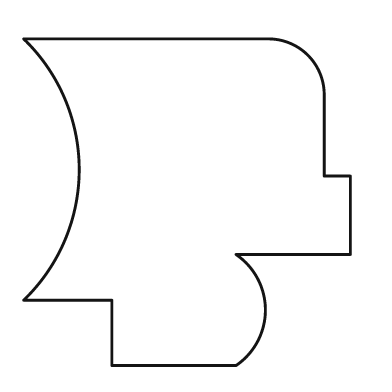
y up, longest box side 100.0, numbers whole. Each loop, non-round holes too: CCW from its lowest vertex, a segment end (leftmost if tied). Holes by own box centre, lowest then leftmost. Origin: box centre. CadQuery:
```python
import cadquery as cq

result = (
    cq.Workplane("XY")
    .moveTo(-23.0, -50.0)
    .lineTo(15.0, -50.0)
    .threePointArc((24.0, -33.0), (15.0, -16.0))
    .lineTo(50.0, -16.0)
    .lineTo(50.0, 8.0)
    .lineTo(42.0, 8.0)
    .lineTo(42.0, 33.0)
    .threePointArc((37.0, 45.0), (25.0, 50.0))
    .lineTo(-50.0, 50.0)
    .threePointArc((-33.0, 10.0), (-50.0, -30.0))
    .lineTo(-23.0, -30.0)
    .close()
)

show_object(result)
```